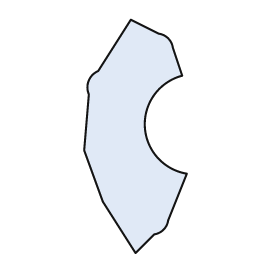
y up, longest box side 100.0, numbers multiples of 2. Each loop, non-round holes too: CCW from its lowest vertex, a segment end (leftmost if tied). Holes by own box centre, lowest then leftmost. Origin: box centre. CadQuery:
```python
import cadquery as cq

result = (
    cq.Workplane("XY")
    .moveTo(0.0, -50.0)
    .lineTo(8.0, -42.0)
    .threePointArc((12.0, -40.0), (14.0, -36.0))
    .lineTo(22.0, -16.0)
    .threePointArc((4.0, 4.0), (20.0, 26.0))
    .lineTo(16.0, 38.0)
    .threePointArc((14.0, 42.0), (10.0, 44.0))
    .lineTo(-2.0, 50.0)
    .lineTo(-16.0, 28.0)
    .threePointArc((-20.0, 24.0), (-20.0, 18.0))
    .lineTo(-22.0, -6.0)
    .lineTo(-14.0, -28.0)
    .close()
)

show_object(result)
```